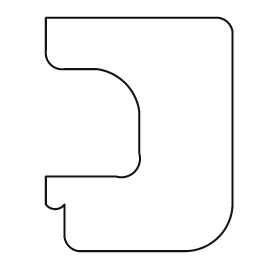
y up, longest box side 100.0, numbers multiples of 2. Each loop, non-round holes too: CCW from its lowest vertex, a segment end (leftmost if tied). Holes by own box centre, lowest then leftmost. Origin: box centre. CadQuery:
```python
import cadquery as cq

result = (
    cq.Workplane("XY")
    .moveTo(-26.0, -50.0)
    .lineTo(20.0, -50.0)
    .threePointArc((34.0, -44.0), (40.0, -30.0))
    .lineTo(40.0, 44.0)
    .threePointArc((38.0, 48.0), (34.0, 50.0))
    .lineTo(-40.0, 50.0)
    .lineTo(-40.0, 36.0)
    .threePointArc((-38.0, 30.0), (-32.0, 28.0))
    .lineTo(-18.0, 28.0)
    .threePointArc((-6.0, 22.0), (0.0, 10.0))
    .lineTo(0.0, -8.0)
    .threePointArc((-2.0, -16.0), (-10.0, -18.0))
    .lineTo(-40.0, -18.0)
    .lineTo(-40.0, -30.0)
    .threePointArc((-36.0, -32.0), (-32.0, -30.0))
    .lineTo(-32.0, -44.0)
    .threePointArc((-30.0, -48.0), (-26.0, -50.0))
    .close()
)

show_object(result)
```